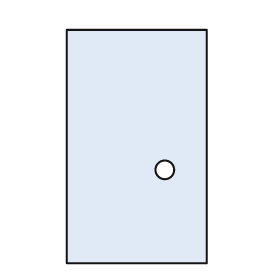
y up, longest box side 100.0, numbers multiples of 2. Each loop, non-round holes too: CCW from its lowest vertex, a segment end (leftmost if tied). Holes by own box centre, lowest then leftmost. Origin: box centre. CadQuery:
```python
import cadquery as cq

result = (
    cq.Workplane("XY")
    .moveTo(-30.0, -50.0)
    .lineTo(30.0, -50.0)
    .lineTo(30.0, 50.0)
    .lineTo(-30.0, 50.0)
    .close()
    .moveTo(12.0, -10.0)
    .circle(4.0)
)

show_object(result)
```